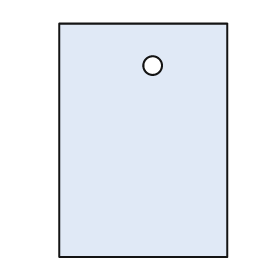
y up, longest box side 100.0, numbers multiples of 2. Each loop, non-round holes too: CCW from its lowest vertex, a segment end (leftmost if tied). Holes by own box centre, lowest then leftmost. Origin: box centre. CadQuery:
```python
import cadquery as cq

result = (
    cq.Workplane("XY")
    .moveTo(-36.0, -50.0)
    .lineTo(36.0, -50.0)
    .lineTo(36.0, 50.0)
    .lineTo(-36.0, 50.0)
    .close()
    .moveTo(4.0, 32.0)
    .circle(4.0)
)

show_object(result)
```